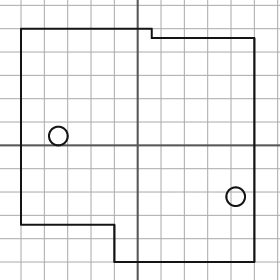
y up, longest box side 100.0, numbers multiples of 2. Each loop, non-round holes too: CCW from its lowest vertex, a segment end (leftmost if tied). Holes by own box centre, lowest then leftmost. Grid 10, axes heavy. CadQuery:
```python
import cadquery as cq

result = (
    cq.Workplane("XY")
    .moveTo(-10.0, -50.0)
    .lineTo(50.0, -50.0)
    .lineTo(50.0, 46.0)
    .lineTo(6.0, 46.0)
    .lineTo(6.0, 50.0)
    .lineTo(-50.0, 50.0)
    .lineTo(-50.0, -34.0)
    .lineTo(-10.0, -34.0)
    .close()
    .moveTo(42.0, -22.0)
    .circle(4.0)
    .moveTo(-34.0, 4.0)
    .circle(4.0)
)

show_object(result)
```